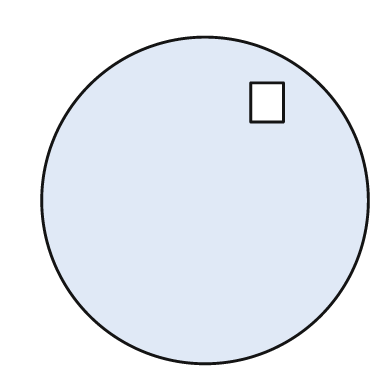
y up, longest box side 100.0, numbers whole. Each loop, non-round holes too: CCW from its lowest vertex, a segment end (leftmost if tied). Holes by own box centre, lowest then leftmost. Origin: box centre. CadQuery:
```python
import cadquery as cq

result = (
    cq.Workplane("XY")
    .moveTo(0.0, 0.0)
    .circle(50.0)
    .moveTo(14.0, 24.0)
    .lineTo(24.0, 24.0)
    .lineTo(24.0, 36.0)
    .lineTo(14.0, 36.0)
    .close()
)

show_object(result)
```